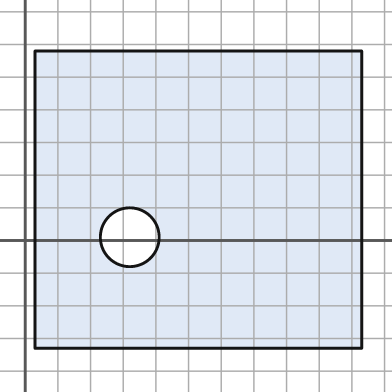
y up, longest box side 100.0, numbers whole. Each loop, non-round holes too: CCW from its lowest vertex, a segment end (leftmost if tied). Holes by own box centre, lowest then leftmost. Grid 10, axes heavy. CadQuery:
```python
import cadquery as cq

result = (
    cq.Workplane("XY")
    .moveTo(3.0, -33.0)
    .lineTo(103.0, -33.0)
    .lineTo(103.0, 58.0)
    .lineTo(3.0, 58.0)
    .close()
    .moveTo(32.0, 1.0)
    .circle(9.0)
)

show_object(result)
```